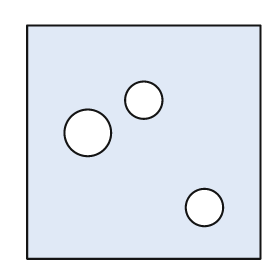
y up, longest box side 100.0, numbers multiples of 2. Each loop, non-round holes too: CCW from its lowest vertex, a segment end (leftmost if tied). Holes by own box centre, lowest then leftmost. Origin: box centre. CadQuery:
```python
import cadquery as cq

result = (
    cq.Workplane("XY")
    .moveTo(-50.0, -50.0)
    .lineTo(50.0, -50.0)
    .lineTo(50.0, 50.0)
    .lineTo(-50.0, 50.0)
    .close()
    .moveTo(26.0, -28.0)
    .circle(8.0)
    .moveTo(-24.0, 4.0)
    .circle(10.0)
    .moveTo(0.0, 18.0)
    .circle(8.0)
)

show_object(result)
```